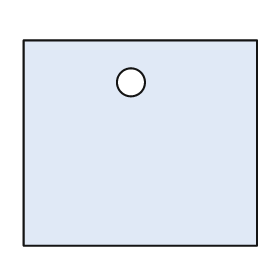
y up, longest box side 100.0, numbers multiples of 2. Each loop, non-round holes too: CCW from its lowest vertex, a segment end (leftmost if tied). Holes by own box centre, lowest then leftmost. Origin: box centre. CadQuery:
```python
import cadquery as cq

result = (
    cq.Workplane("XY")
    .moveTo(-50.0, -44.0)
    .lineTo(50.0, -44.0)
    .lineTo(50.0, 44.0)
    .lineTo(-50.0, 44.0)
    .close()
    .moveTo(-4.0, 26.0)
    .circle(6.0)
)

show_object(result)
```